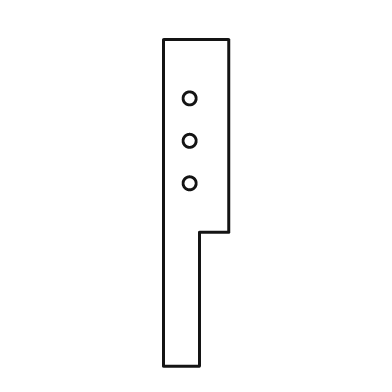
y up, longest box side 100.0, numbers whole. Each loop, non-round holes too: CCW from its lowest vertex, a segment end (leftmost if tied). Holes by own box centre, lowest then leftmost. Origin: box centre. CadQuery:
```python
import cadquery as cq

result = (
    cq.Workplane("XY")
    .moveTo(-10.0, -50.0)
    .lineTo(1.0, -50.0)
    .lineTo(1.0, -9.0)
    .lineTo(10.0, -9.0)
    .lineTo(10.0, 50.0)
    .lineTo(-10.0, 50.0)
    .close()
    .moveTo(-2.0, 6.0)
    .circle(2.0)
    .moveTo(-2.0, 19.0)
    .circle(2.0)
    .moveTo(-2.0, 32.0)
    .circle(2.0)
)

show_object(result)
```